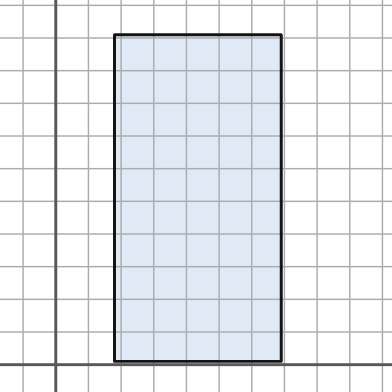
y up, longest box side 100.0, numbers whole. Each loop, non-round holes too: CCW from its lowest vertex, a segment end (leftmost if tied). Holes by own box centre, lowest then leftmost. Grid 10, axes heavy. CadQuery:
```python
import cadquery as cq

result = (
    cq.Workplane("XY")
    .moveTo(18.0, 1.0)
    .lineTo(69.0, 1.0)
    .lineTo(69.0, 101.0)
    .lineTo(18.0, 101.0)
    .close()
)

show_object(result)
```